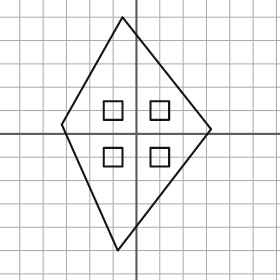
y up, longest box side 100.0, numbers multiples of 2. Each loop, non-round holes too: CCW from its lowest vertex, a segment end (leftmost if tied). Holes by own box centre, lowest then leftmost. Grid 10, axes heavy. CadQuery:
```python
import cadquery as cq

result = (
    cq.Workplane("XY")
    .moveTo(-8.0, -50.0)
    .lineTo(32.0, 2.0)
    .lineTo(-6.0, 50.0)
    .lineTo(-32.0, 4.0)
    .close()
    .moveTo(-14.0, -14.0)
    .lineTo(-6.0, -14.0)
    .lineTo(-6.0, -6.0)
    .lineTo(-14.0, -6.0)
    .close()
    .moveTo(6.0, -14.0)
    .lineTo(14.0, -14.0)
    .lineTo(14.0, -6.0)
    .lineTo(6.0, -6.0)
    .close()
    .moveTo(-14.0, 6.0)
    .lineTo(-6.0, 6.0)
    .lineTo(-6.0, 14.0)
    .lineTo(-14.0, 14.0)
    .close()
    .moveTo(6.0, 6.0)
    .lineTo(14.0, 6.0)
    .lineTo(14.0, 14.0)
    .lineTo(6.0, 14.0)
    .close()
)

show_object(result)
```